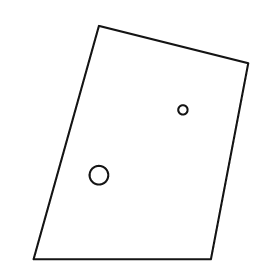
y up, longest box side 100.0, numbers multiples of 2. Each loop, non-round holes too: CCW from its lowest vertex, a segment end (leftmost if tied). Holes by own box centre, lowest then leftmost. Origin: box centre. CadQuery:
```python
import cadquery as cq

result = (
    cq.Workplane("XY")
    .moveTo(-46.0, -50.0)
    .lineTo(30.0, -50.0)
    .lineTo(46.0, 34.0)
    .lineTo(-18.0, 50.0)
    .close()
    .moveTo(-18.0, -14.0)
    .circle(4.0)
    .moveTo(18.0, 14.0)
    .circle(2.0)
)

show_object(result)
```